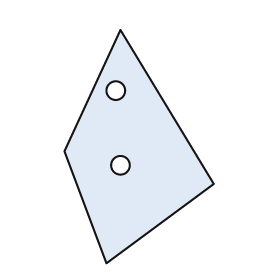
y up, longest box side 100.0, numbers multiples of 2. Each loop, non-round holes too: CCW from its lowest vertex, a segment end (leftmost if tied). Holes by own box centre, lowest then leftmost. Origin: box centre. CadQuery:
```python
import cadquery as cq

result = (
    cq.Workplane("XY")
    .moveTo(-14.0, -50.0)
    .lineTo(32.0, -16.0)
    .lineTo(-8.0, 50.0)
    .lineTo(-32.0, -2.0)
    .close()
    .moveTo(-8.0, -8.0)
    .circle(4.0)
    .moveTo(-10.0, 24.0)
    .circle(4.0)
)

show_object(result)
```